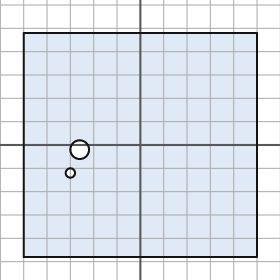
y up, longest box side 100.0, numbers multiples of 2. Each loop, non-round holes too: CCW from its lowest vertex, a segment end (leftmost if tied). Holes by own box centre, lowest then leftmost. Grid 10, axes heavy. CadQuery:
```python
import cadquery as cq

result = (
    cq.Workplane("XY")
    .moveTo(-50.0, -48.0)
    .lineTo(50.0, -48.0)
    .lineTo(50.0, 48.0)
    .lineTo(-50.0, 48.0)
    .close()
    .moveTo(-30.0, -12.0)
    .circle(2.0)
    .moveTo(-26.0, -2.0)
    .circle(4.0)
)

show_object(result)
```